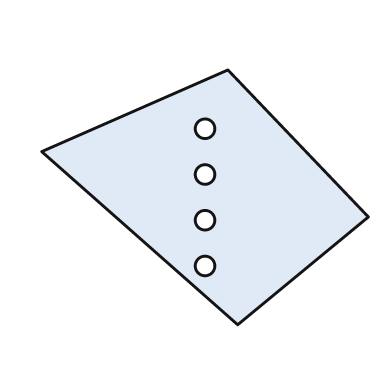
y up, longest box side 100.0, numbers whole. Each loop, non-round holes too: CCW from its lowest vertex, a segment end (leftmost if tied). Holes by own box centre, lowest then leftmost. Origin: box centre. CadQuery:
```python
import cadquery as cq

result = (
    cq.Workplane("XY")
    .moveTo(10.0, -39.0)
    .lineTo(50.0, -6.0)
    .lineTo(7.0, 39.0)
    .lineTo(-50.0, 14.0)
    .close()
    .moveTo(0.0, -21.0)
    .circle(3.0)
    .moveTo(0.0, -7.0)
    .circle(3.0)
    .moveTo(0.0, 7.0)
    .circle(3.0)
    .moveTo(0.0, 21.0)
    .circle(3.0)
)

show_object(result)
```